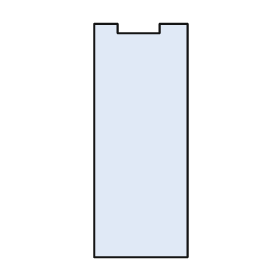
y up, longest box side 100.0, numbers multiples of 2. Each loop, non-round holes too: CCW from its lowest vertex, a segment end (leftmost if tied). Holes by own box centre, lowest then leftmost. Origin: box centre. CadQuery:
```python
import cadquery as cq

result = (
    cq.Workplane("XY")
    .moveTo(-20.0, -50.0)
    .lineTo(20.0, -50.0)
    .lineTo(20.0, 50.0)
    .lineTo(8.0, 50.0)
    .lineTo(8.0, 46.0)
    .lineTo(-10.0, 46.0)
    .lineTo(-10.0, 50.0)
    .lineTo(-20.0, 50.0)
    .close()
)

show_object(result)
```